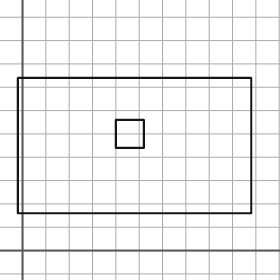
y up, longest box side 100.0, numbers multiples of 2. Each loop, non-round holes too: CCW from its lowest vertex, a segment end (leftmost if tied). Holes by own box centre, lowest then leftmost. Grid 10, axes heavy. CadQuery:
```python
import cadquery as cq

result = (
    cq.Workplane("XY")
    .moveTo(-2.0, 16.0)
    .lineTo(98.0, 16.0)
    .lineTo(98.0, 74.0)
    .lineTo(-2.0, 74.0)
    .close()
    .moveTo(40.0, 44.0)
    .lineTo(52.0, 44.0)
    .lineTo(52.0, 56.0)
    .lineTo(40.0, 56.0)
    .close()
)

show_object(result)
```